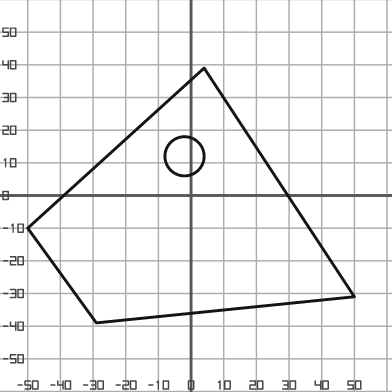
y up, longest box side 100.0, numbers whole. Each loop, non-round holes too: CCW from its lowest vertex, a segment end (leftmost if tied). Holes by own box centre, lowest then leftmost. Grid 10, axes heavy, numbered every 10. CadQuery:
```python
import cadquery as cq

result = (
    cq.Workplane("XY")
    .moveTo(-29.0, -39.0)
    .lineTo(50.0, -31.0)
    .lineTo(4.0, 39.0)
    .lineTo(-50.0, -10.0)
    .close()
    .moveTo(-2.0, 12.0)
    .circle(6.0)
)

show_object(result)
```